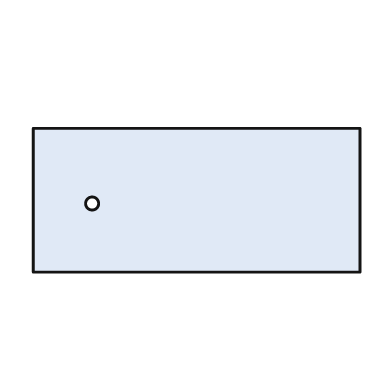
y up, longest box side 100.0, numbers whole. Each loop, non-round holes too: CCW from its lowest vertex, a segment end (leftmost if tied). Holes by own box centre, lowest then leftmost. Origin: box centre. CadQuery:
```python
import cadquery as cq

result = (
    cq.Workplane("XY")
    .moveTo(-50.0, -22.0)
    .lineTo(50.0, -22.0)
    .lineTo(50.0, 22.0)
    .lineTo(-50.0, 22.0)
    .close()
    .moveTo(-32.0, -1.0)
    .circle(2.0)
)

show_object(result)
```